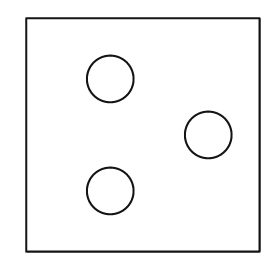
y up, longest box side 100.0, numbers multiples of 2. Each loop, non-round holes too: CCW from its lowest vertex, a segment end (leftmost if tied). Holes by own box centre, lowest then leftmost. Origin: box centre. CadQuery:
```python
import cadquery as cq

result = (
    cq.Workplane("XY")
    .moveTo(-50.0, -50.0)
    .lineTo(50.0, -50.0)
    .lineTo(50.0, 50.0)
    .lineTo(-50.0, 50.0)
    .close()
    .moveTo(-14.0, -24.0)
    .circle(10.0)
    .moveTo(28.0, 0.0)
    .circle(10.0)
    .moveTo(-14.0, 24.0)
    .circle(10.0)
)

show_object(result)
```